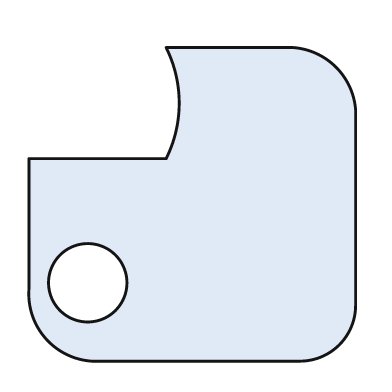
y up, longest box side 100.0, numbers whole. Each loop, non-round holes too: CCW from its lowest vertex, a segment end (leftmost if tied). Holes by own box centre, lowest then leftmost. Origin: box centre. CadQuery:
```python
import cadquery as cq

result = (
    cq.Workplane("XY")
    .moveTo(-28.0, -48.0)
    .lineTo(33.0, -48.0)
    .threePointArc((45.0, -43.0), (50.0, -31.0))
    .lineTo(50.0, 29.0)
    .threePointArc((44.0, 42.0), (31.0, 48.0))
    .lineTo(-8.0, 48.0)
    .threePointArc((-4.0, 31.0), (-8.0, 14.0))
    .lineTo(-50.0, 14.0)
    .lineTo(-50.0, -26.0)
    .threePointArc((-44.0, -42.0), (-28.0, -48.0))
    .close()
    .moveTo(-32.0, -24.0)
    .circle(12.0)
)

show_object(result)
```